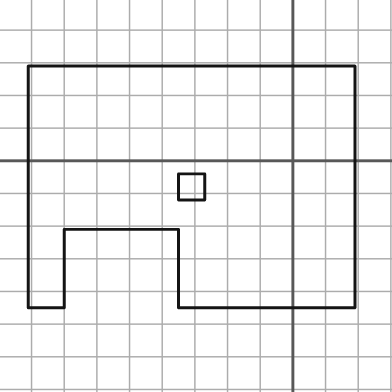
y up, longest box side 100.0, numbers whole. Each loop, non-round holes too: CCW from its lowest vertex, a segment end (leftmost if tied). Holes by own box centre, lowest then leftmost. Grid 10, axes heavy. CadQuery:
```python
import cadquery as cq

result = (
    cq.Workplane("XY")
    .moveTo(-81.0, -45.0)
    .lineTo(-70.0, -45.0)
    .lineTo(-70.0, -21.0)
    .lineTo(-35.0, -21.0)
    .lineTo(-35.0, -45.0)
    .lineTo(19.0, -45.0)
    .lineTo(19.0, 29.0)
    .lineTo(-81.0, 29.0)
    .close()
    .moveTo(-35.0, -12.0)
    .lineTo(-27.0, -12.0)
    .lineTo(-27.0, -4.0)
    .lineTo(-35.0, -4.0)
    .close()
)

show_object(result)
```